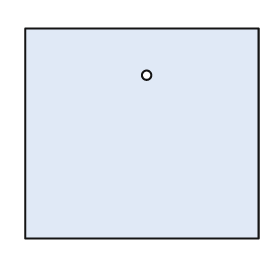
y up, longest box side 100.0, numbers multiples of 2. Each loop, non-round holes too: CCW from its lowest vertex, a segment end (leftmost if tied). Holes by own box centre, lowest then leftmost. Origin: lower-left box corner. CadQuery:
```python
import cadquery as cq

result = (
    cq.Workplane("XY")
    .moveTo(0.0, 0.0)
    .lineTo(100.0, 0.0)
    .lineTo(100.0, 90.0)
    .lineTo(0.0, 90.0)
    .close()
    .moveTo(52.0, 70.0)
    .circle(2.0)
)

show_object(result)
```